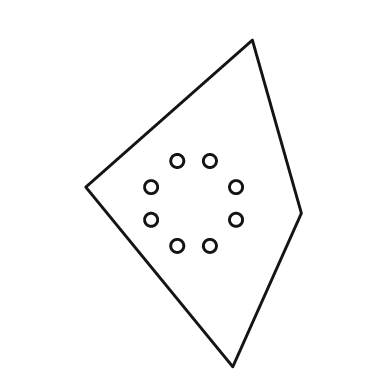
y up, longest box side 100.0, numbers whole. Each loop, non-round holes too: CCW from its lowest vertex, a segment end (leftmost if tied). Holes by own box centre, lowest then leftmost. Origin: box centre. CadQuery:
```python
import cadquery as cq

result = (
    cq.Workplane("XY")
    .moveTo(12.0, -50.0)
    .lineTo(33.0, -3.0)
    .lineTo(18.0, 50.0)
    .lineTo(-33.0, 5.0)
    .close()
    .moveTo(-5.0, -13.0)
    .circle(2.0)
    .moveTo(5.0, -13.0)
    .circle(2.0)
    .moveTo(-13.0, -5.0)
    .circle(2.0)
    .moveTo(13.0, -5.0)
    .circle(2.0)
    .moveTo(-13.0, 5.0)
    .circle(2.0)
    .moveTo(13.0, 5.0)
    .circle(2.0)
    .moveTo(-5.0, 13.0)
    .circle(2.0)
    .moveTo(5.0, 13.0)
    .circle(2.0)
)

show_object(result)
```